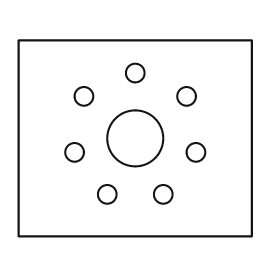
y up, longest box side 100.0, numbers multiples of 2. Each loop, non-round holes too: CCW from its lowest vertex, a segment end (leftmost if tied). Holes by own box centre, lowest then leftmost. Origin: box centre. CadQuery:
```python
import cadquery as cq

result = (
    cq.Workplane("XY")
    .moveTo(-50.0, -42.0)
    .lineTo(50.0, -42.0)
    .lineTo(50.0, 42.0)
    .lineTo(-50.0, 42.0)
    .close()
    .moveTo(-12.0, -24.0)
    .circle(4.0)
    .moveTo(12.0, -24.0)
    .circle(4.0)
    .moveTo(-26.0, -6.0)
    .circle(4.0)
    .moveTo(26.0, -6.0)
    .circle(4.0)
    .moveTo(0.0, 0.0)
    .circle(12.0)
    .moveTo(-22.0, 18.0)
    .circle(4.0)
    .moveTo(22.0, 18.0)
    .circle(4.0)
    .moveTo(0.0, 28.0)
    .circle(4.0)
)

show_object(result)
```